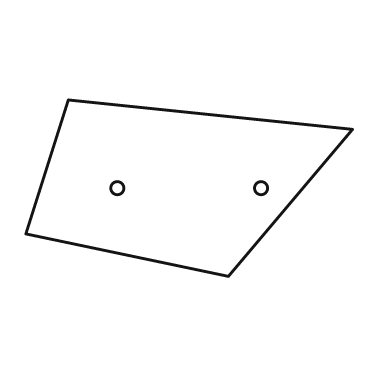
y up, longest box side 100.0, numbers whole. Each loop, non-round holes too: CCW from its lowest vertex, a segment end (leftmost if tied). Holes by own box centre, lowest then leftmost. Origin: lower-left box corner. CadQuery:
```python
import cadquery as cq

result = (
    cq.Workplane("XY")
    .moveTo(62.0, 0.0)
    .lineTo(100.0, 45.0)
    .lineTo(13.0, 54.0)
    .lineTo(0.0, 13.0)
    .close()
    .moveTo(28.0, 27.0)
    .circle(2.0)
    .moveTo(72.0, 27.0)
    .circle(2.0)
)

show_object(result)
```